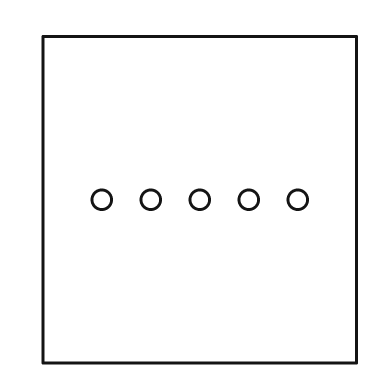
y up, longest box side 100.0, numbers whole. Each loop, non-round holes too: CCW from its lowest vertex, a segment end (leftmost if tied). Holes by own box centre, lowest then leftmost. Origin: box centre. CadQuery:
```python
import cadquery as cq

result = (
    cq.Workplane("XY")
    .moveTo(-48.0, -50.0)
    .lineTo(48.0, -50.0)
    .lineTo(48.0, 50.0)
    .lineTo(-48.0, 50.0)
    .close()
    .moveTo(-30.0, 0.0)
    .circle(3.0)
    .moveTo(-15.0, 0.0)
    .circle(3.0)
    .moveTo(0.0, 0.0)
    .circle(3.0)
    .moveTo(15.0, 0.0)
    .circle(3.0)
    .moveTo(30.0, 0.0)
    .circle(3.0)
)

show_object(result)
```